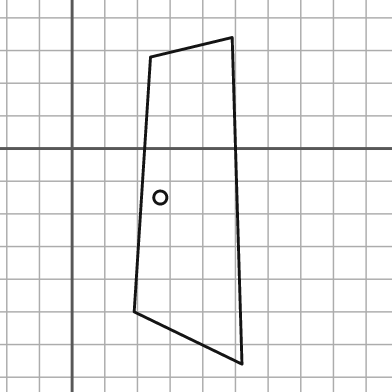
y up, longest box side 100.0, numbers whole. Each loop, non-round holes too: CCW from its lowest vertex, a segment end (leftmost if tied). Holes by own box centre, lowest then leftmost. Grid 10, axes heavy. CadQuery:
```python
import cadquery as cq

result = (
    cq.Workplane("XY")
    .moveTo(52.0, -66.0)
    .lineTo(49.0, 34.0)
    .lineTo(24.0, 28.0)
    .lineTo(19.0, -50.0)
    .close()
    .moveTo(27.0, -15.0)
    .circle(2.0)
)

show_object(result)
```